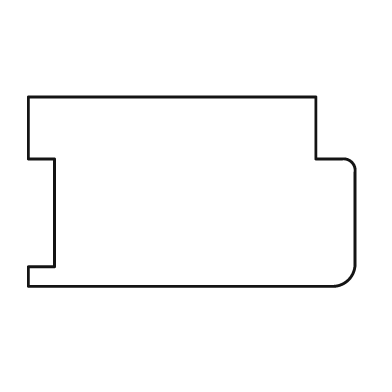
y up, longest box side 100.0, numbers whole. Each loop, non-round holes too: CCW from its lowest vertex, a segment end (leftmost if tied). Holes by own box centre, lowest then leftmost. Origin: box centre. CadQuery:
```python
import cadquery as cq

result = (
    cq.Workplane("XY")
    .moveTo(-50.0, -29.0)
    .lineTo(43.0, -29.0)
    .threePointArc((48.0, -27.0), (50.0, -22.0))
    .lineTo(50.0, 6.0)
    .threePointArc((49.0, 9.0), (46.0, 10.0))
    .lineTo(38.0, 10.0)
    .lineTo(38.0, 29.0)
    .lineTo(-50.0, 29.0)
    .lineTo(-50.0, 10.0)
    .lineTo(-42.0, 10.0)
    .lineTo(-42.0, -23.0)
    .lineTo(-50.0, -23.0)
    .close()
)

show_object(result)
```